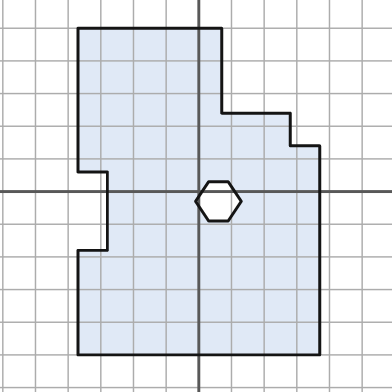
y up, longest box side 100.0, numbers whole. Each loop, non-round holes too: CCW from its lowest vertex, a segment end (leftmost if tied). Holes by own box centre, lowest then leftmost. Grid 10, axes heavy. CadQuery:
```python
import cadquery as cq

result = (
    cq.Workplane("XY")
    .moveTo(-37.0, -50.0)
    .lineTo(37.0, -50.0)
    .lineTo(37.0, 14.0)
    .lineTo(28.0, 14.0)
    .lineTo(28.0, 24.0)
    .lineTo(7.0, 24.0)
    .lineTo(7.0, 50.0)
    .lineTo(-37.0, 50.0)
    .lineTo(-37.0, 6.0)
    .lineTo(-28.0, 6.0)
    .lineTo(-28.0, -18.0)
    .lineTo(-37.0, -18.0)
    .close()
    .moveTo(3.0, -9.0)
    .lineTo(9.0, -9.0)
    .lineTo(13.0, -3.0)
    .lineTo(9.0, 3.0)
    .lineTo(3.0, 3.0)
    .lineTo(-1.0, -3.0)
    .close()
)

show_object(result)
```